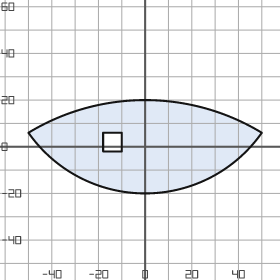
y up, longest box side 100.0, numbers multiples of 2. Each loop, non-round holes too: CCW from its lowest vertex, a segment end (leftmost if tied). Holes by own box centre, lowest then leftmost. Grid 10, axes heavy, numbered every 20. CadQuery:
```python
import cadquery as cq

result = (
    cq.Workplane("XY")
    .moveTo(-50.0, 6.0)
    .threePointArc((0.0, -20.0), (50.0, 6.0))
    .threePointArc((0.0, 20.0), (-50.0, 6.0))
    .close()
    .moveTo(-18.0, -2.0)
    .lineTo(-10.0, -2.0)
    .lineTo(-10.0, 6.0)
    .lineTo(-18.0, 6.0)
    .close()
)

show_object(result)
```